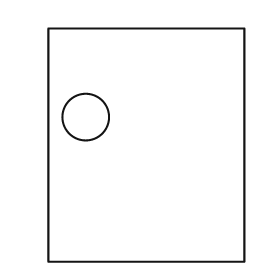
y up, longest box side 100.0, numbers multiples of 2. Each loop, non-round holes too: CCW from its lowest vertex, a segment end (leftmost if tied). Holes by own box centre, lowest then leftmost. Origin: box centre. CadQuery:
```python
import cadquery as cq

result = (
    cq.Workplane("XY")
    .moveTo(-42.0, -50.0)
    .lineTo(42.0, -50.0)
    .lineTo(42.0, 50.0)
    .lineTo(-42.0, 50.0)
    .close()
    .moveTo(-26.0, 12.0)
    .circle(10.0)
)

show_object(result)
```